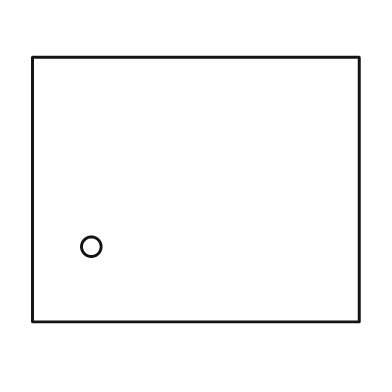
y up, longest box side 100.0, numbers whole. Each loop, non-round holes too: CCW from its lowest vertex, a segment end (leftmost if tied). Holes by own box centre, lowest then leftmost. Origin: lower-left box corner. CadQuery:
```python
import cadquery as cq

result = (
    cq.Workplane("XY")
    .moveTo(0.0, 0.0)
    .lineTo(100.0, 0.0)
    .lineTo(100.0, 81.0)
    .lineTo(0.0, 81.0)
    .close()
    .moveTo(18.0, 23.0)
    .circle(3.0)
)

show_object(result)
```